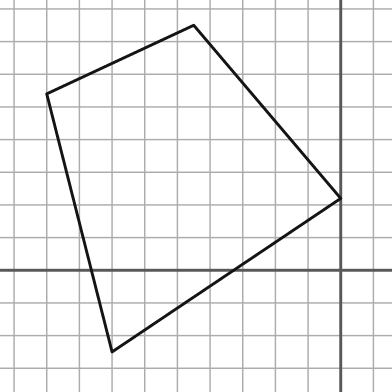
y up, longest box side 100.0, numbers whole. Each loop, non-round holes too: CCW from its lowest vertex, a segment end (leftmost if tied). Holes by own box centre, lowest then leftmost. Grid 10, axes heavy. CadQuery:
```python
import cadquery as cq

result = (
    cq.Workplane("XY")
    .moveTo(-70.0, -25.0)
    .lineTo(0.0, 22.0)
    .lineTo(-45.0, 75.0)
    .lineTo(-90.0, 54.0)
    .close()
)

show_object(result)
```